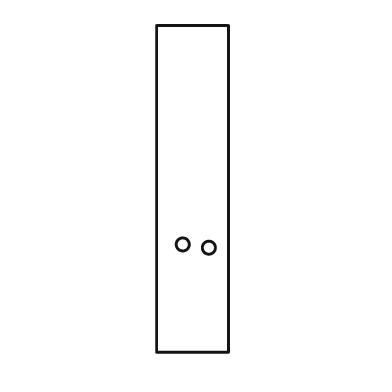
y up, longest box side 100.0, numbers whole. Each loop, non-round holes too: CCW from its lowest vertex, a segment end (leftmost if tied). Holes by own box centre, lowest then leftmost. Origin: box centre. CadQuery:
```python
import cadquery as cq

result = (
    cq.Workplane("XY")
    .moveTo(-11.0, -50.0)
    .lineTo(11.0, -50.0)
    .lineTo(11.0, 50.0)
    .lineTo(-11.0, 50.0)
    .close()
    .moveTo(5.0, -18.0)
    .circle(2.0)
    .moveTo(-3.0, -17.0)
    .circle(2.0)
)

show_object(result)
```